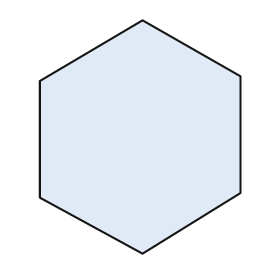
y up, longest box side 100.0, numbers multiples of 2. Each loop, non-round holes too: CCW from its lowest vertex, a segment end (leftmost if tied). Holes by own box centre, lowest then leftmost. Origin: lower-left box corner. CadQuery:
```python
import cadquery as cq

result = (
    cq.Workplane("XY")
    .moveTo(44.0, 0.0)
    .lineTo(86.0, 26.0)
    .lineTo(86.0, 76.0)
    .lineTo(44.0, 100.0)
    .lineTo(0.0, 74.0)
    .lineTo(0.0, 24.0)
    .close()
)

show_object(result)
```